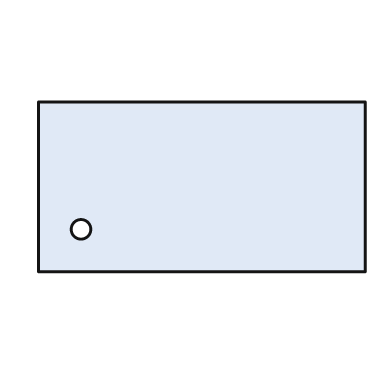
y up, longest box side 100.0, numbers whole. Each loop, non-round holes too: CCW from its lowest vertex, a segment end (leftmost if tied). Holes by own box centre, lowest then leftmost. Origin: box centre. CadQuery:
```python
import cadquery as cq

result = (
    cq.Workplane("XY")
    .moveTo(-50.0, -26.0)
    .lineTo(50.0, -26.0)
    .lineTo(50.0, 26.0)
    .lineTo(-50.0, 26.0)
    .close()
    .moveTo(-37.0, -13.0)
    .circle(3.0)
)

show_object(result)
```